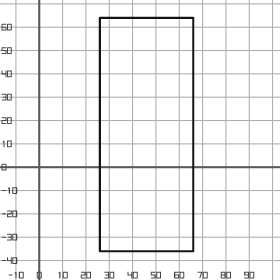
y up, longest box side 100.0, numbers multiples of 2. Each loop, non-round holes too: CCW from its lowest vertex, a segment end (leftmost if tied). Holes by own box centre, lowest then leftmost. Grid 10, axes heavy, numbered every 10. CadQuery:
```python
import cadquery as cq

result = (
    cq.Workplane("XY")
    .moveTo(26.0, -36.0)
    .lineTo(66.0, -36.0)
    .lineTo(66.0, 64.0)
    .lineTo(26.0, 64.0)
    .close()
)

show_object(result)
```